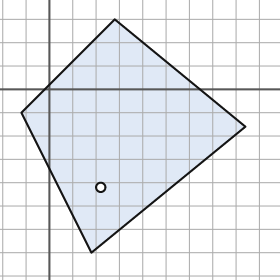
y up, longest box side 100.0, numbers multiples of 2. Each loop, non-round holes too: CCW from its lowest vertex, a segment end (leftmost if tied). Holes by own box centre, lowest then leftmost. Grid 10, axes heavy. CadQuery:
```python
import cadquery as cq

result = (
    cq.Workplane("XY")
    .moveTo(18.0, -70.0)
    .lineTo(84.0, -16.0)
    .lineTo(28.0, 30.0)
    .lineTo(-12.0, -10.0)
    .close()
    .moveTo(22.0, -42.0)
    .circle(2.0)
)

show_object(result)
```